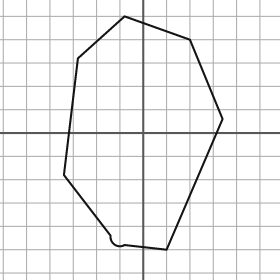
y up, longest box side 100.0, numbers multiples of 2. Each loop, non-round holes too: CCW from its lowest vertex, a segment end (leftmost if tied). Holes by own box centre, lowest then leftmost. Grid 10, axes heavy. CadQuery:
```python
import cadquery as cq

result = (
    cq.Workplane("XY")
    .moveTo(10.0, -50.0)
    .lineTo(34.0, 6.0)
    .lineTo(20.0, 40.0)
    .lineTo(-8.0, 50.0)
    .lineTo(-28.0, 32.0)
    .lineTo(-34.0, -18.0)
    .lineTo(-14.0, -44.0)
    .threePointArc((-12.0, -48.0), (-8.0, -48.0))
    .close()
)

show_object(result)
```